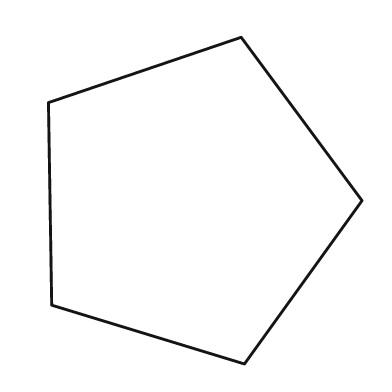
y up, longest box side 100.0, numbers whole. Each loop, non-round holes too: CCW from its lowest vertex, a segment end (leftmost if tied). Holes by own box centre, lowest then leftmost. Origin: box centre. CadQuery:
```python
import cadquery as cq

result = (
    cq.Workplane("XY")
    .moveTo(12.0, -50.0)
    .lineTo(48.0, 0.0)
    .lineTo(11.0, 50.0)
    .lineTo(-48.0, 30.0)
    .lineTo(-47.0, -32.0)
    .close()
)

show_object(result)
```